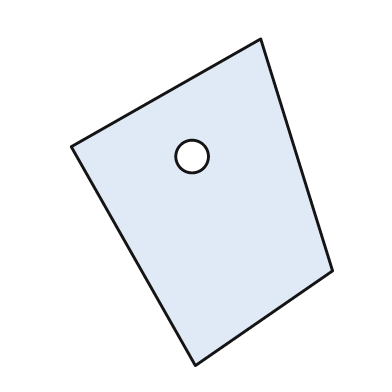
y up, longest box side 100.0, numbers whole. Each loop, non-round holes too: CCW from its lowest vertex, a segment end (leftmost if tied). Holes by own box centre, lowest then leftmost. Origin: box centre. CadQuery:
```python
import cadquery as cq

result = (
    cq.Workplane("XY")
    .moveTo(-2.0, -50.0)
    .lineTo(40.0, -21.0)
    .lineTo(18.0, 50.0)
    .lineTo(-40.0, 17.0)
    .close()
    .moveTo(-3.0, 14.0)
    .circle(5.0)
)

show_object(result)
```